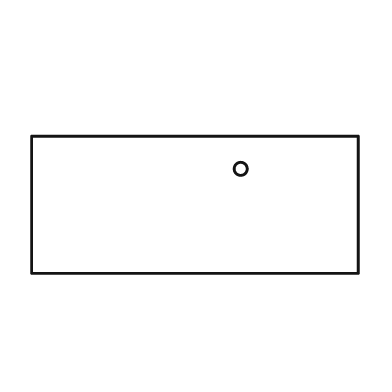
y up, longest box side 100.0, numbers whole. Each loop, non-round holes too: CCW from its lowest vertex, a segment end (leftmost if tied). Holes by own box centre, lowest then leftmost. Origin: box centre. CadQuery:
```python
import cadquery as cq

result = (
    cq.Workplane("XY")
    .moveTo(-50.0, -21.0)
    .lineTo(50.0, -21.0)
    .lineTo(50.0, 21.0)
    .lineTo(-50.0, 21.0)
    .close()
    .moveTo(14.0, 11.0)
    .circle(2.0)
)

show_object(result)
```